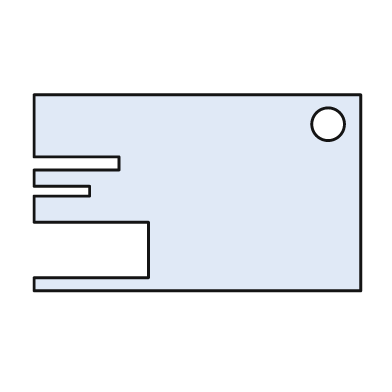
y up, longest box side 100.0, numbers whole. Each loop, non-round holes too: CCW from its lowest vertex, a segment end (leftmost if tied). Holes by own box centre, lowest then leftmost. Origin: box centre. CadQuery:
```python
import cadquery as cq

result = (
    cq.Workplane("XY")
    .moveTo(-50.0, -30.0)
    .lineTo(50.0, -30.0)
    .lineTo(50.0, 30.0)
    .lineTo(-50.0, 30.0)
    .lineTo(-50.0, 11.0)
    .lineTo(-24.0, 11.0)
    .lineTo(-24.0, 7.0)
    .lineTo(-50.0, 7.0)
    .lineTo(-50.0, 2.0)
    .lineTo(-33.0, 2.0)
    .lineTo(-33.0, -1.0)
    .lineTo(-50.0, -1.0)
    .lineTo(-50.0, -9.0)
    .lineTo(-15.0, -9.0)
    .lineTo(-15.0, -26.0)
    .lineTo(-50.0, -26.0)
    .close()
    .moveTo(40.0, 21.0)
    .circle(5.0)
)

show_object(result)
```